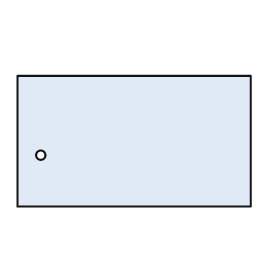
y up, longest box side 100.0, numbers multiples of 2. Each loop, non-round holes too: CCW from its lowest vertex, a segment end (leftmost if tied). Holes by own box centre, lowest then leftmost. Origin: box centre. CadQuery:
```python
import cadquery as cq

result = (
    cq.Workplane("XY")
    .moveTo(-50.0, -28.0)
    .lineTo(50.0, -28.0)
    .lineTo(50.0, 28.0)
    .lineTo(-50.0, 28.0)
    .close()
    .moveTo(-40.0, -6.0)
    .circle(2.0)
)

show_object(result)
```